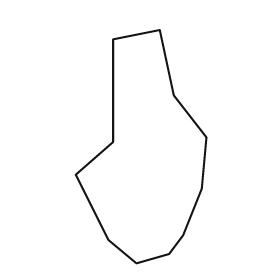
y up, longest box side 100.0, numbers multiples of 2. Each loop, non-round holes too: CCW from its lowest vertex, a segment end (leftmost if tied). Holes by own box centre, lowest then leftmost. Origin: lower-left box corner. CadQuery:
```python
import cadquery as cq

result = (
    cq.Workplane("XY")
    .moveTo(26.0, 0.0)
    .lineTo(40.0, 4.0)
    .lineTo(46.0, 12.0)
    .lineTo(54.0, 32.0)
    .lineTo(56.0, 54.0)
    .lineTo(42.0, 72.0)
    .lineTo(36.0, 100.0)
    .lineTo(16.0, 96.0)
    .lineTo(16.0, 52.0)
    .lineTo(0.0, 38.0)
    .lineTo(14.0, 10.0)
    .close()
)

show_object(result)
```